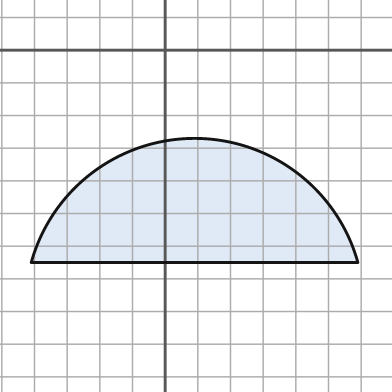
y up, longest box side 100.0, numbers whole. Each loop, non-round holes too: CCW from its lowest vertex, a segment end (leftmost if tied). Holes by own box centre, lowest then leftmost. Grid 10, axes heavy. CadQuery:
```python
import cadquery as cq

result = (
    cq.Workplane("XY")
    .moveTo(-41.0, -65.0)
    .lineTo(59.0, -65.0)
    .threePointArc((9.0, -27.0), (-41.0, -65.0))
    .close()
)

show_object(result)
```